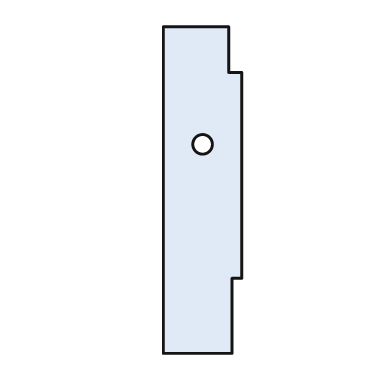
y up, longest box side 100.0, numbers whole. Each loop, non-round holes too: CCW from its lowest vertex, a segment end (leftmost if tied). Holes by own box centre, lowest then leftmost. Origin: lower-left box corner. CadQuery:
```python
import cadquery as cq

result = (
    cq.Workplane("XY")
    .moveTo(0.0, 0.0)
    .lineTo(21.0, 0.0)
    .lineTo(21.0, 23.0)
    .lineTo(24.0, 23.0)
    .lineTo(24.0, 86.0)
    .lineTo(20.0, 86.0)
    .lineTo(20.0, 100.0)
    .lineTo(0.0, 100.0)
    .close()
    .moveTo(12.0, 64.0)
    .circle(3.0)
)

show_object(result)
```